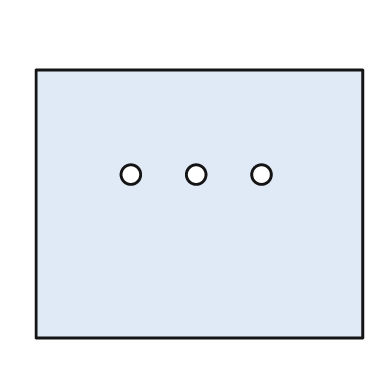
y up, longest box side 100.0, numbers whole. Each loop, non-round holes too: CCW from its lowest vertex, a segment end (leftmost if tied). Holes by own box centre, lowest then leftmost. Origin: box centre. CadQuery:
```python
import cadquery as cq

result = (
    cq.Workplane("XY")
    .moveTo(-50.0, -41.0)
    .lineTo(50.0, -41.0)
    .lineTo(50.0, 41.0)
    .lineTo(-50.0, 41.0)
    .close()
    .moveTo(-21.0, 9.0)
    .circle(3.0)
    .moveTo(-1.0, 9.0)
    .circle(3.0)
    .moveTo(19.0, 9.0)
    .circle(3.0)
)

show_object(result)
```